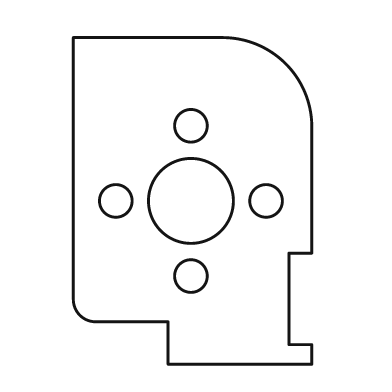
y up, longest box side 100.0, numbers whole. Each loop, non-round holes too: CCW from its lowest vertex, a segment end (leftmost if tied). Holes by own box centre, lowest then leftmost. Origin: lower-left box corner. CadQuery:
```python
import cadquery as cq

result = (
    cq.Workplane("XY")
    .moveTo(29.0, 0.0)
    .lineTo(73.0, 0.0)
    .lineTo(73.0, 6.0)
    .lineTo(66.0, 6.0)
    .lineTo(66.0, 34.0)
    .lineTo(73.0, 34.0)
    .lineTo(73.0, 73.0)
    .threePointArc((65.0, 92.0), (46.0, 100.0))
    .lineTo(0.0, 100.0)
    .lineTo(0.0, 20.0)
    .threePointArc((2.0, 15.0), (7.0, 13.0))
    .lineTo(29.0, 13.0)
    .close()
    .moveTo(36.0, 27.0)
    .circle(5.0)
    .moveTo(13.0, 50.0)
    .circle(5.0)
    .moveTo(36.0, 50.0)
    .circle(13.0)
    .moveTo(59.0, 50.0)
    .circle(5.0)
    .moveTo(36.0, 73.0)
    .circle(5.0)
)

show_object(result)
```